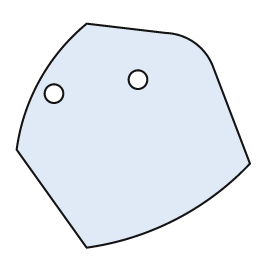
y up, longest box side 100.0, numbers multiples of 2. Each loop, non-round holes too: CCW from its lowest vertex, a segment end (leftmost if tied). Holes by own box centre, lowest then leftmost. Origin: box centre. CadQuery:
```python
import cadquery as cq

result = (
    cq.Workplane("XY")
    .moveTo(-20.0, -48.0)
    .threePointArc((18.0, -36.0), (50.0, -12.0))
    .lineTo(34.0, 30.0)
    .threePointArc((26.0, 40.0), (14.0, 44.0))
    .lineTo(-20.0, 48.0)
    .threePointArc((-40.0, 24.0), (-50.0, -6.0))
    .close()
    .moveTo(-34.0, 18.0)
    .circle(4.0)
    .moveTo(2.0, 24.0)
    .circle(4.0)
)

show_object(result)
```